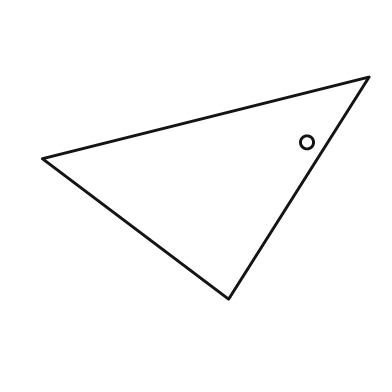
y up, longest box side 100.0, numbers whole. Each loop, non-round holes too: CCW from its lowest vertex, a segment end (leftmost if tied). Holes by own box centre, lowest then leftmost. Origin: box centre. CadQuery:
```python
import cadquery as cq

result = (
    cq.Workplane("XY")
    .moveTo(7.0, -34.0)
    .lineTo(50.0, 34.0)
    .lineTo(-50.0, 9.0)
    .close()
    .moveTo(31.0, 14.0)
    .circle(2.0)
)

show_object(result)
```